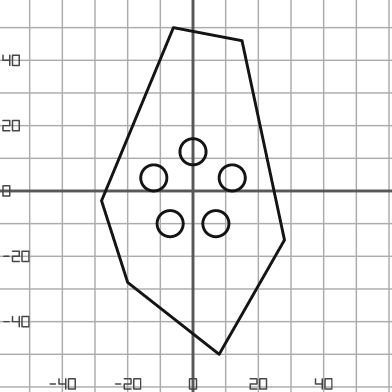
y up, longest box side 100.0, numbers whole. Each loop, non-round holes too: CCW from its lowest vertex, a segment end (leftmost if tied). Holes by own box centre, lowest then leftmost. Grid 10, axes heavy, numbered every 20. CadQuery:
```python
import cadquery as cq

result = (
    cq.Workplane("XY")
    .moveTo(8.0, -50.0)
    .lineTo(28.0, -15.0)
    .lineTo(15.0, 46.0)
    .lineTo(-6.0, 50.0)
    .lineTo(-28.0, -3.0)
    .lineTo(-20.0, -28.0)
    .close()
    .moveTo(-7.0, -10.0)
    .circle(4.0)
    .moveTo(7.0, -10.0)
    .circle(4.0)
    .moveTo(-12.0, 4.0)
    .circle(4.0)
    .moveTo(12.0, 4.0)
    .circle(4.0)
    .moveTo(0.0, 12.0)
    .circle(4.0)
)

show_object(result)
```